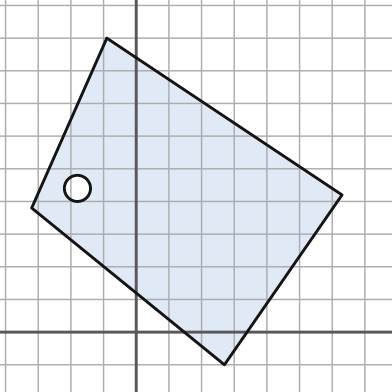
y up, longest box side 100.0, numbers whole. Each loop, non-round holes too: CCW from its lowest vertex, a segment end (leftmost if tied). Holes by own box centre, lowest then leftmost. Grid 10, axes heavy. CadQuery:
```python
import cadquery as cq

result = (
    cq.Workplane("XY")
    .moveTo(27.0, -10.0)
    .lineTo(63.0, 42.0)
    .lineTo(-9.0, 90.0)
    .lineTo(-32.0, 38.0)
    .close()
    .moveTo(-18.0, 44.0)
    .circle(4.0)
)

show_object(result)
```